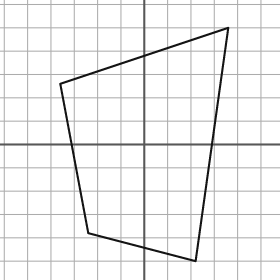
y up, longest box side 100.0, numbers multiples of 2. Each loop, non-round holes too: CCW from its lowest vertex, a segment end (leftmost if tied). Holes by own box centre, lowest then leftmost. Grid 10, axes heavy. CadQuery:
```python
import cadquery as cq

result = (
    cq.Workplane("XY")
    .moveTo(22.0, -50.0)
    .lineTo(36.0, 50.0)
    .lineTo(-36.0, 26.0)
    .lineTo(-24.0, -38.0)
    .close()
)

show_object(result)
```